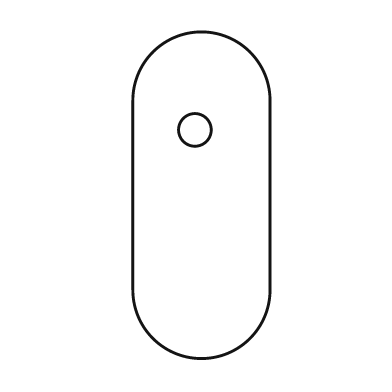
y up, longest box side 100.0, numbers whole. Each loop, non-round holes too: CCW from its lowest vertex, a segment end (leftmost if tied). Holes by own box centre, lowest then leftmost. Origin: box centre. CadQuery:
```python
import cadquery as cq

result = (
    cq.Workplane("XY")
    .moveTo(-21.0, -29.0)
    .threePointArc((0.0, -50.0), (21.0, -29.0))
    .lineTo(21.0, 29.0)
    .threePointArc((0.0, 50.0), (-21.0, 29.0))
    .close()
    .moveTo(-2.0, 20.0)
    .circle(5.0)
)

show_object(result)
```